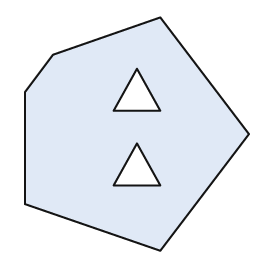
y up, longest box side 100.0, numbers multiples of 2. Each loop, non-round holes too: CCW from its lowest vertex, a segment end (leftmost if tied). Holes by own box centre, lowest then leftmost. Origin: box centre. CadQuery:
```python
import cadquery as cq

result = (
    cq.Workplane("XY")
    .moveTo(10.0, -50.0)
    .lineTo(48.0, 0.0)
    .lineTo(10.0, 50.0)
    .lineTo(-36.0, 34.0)
    .lineTo(-48.0, 18.0)
    .lineTo(-48.0, -30.0)
    .close()
    .moveTo(-10.0, -22.0)
    .lineTo(10.0, -22.0)
    .lineTo(0.0, -4.0)
    .close()
    .moveTo(-10.0, 10.0)
    .lineTo(10.0, 10.0)
    .lineTo(0.0, 28.0)
    .close()
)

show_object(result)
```